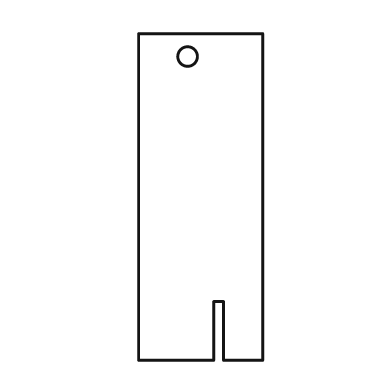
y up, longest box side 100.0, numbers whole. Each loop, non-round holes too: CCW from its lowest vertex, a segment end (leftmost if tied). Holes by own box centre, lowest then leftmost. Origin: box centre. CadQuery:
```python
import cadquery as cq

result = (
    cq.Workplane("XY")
    .moveTo(-19.0, -50.0)
    .lineTo(4.0, -50.0)
    .lineTo(4.0, -32.0)
    .lineTo(7.0, -32.0)
    .lineTo(7.0, -50.0)
    .lineTo(19.0, -50.0)
    .lineTo(19.0, 50.0)
    .lineTo(-19.0, 50.0)
    .close()
    .moveTo(-4.0, 43.0)
    .circle(3.0)
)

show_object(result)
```